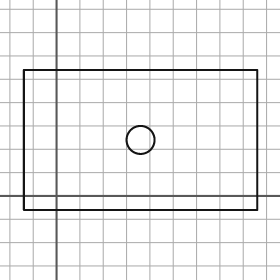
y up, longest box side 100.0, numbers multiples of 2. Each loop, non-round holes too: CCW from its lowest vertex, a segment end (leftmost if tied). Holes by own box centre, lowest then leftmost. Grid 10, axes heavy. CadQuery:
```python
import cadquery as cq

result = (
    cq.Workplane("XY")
    .moveTo(-14.0, -6.0)
    .lineTo(86.0, -6.0)
    .lineTo(86.0, 54.0)
    .lineTo(-14.0, 54.0)
    .close()
    .moveTo(36.0, 24.0)
    .circle(6.0)
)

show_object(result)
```